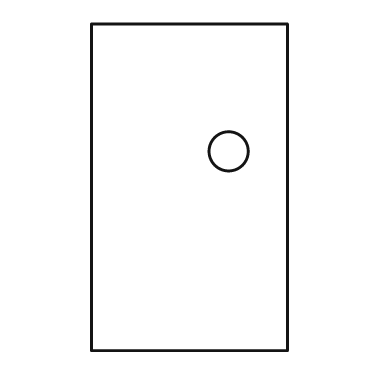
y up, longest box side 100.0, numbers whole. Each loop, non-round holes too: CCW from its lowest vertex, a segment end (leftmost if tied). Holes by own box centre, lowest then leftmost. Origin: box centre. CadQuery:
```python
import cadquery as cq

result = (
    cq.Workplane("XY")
    .moveTo(-30.0, -50.0)
    .lineTo(30.0, -50.0)
    .lineTo(30.0, 50.0)
    .lineTo(-30.0, 50.0)
    .close()
    .moveTo(12.0, 11.0)
    .circle(6.0)
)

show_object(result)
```